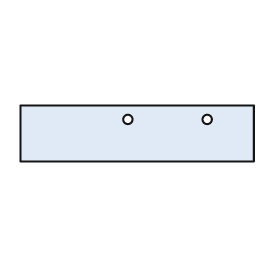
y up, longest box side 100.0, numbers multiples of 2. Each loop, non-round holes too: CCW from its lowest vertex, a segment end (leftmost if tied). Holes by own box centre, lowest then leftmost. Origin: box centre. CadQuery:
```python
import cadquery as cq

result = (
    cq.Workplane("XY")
    .moveTo(-50.0, -12.0)
    .lineTo(50.0, -12.0)
    .lineTo(50.0, 12.0)
    .lineTo(-50.0, 12.0)
    .close()
    .moveTo(-4.0, 6.0)
    .circle(2.0)
    .moveTo(30.0, 6.0)
    .circle(2.0)
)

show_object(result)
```